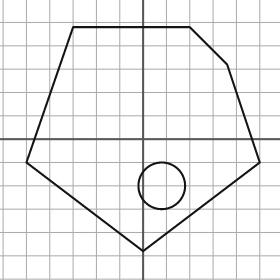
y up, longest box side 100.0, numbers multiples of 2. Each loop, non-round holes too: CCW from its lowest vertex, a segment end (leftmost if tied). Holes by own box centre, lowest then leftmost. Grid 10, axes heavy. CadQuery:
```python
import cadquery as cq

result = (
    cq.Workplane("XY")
    .moveTo(0.0, -48.0)
    .lineTo(50.0, -10.0)
    .lineTo(36.0, 32.0)
    .lineTo(20.0, 48.0)
    .lineTo(-30.0, 48.0)
    .lineTo(-50.0, -10.0)
    .close()
    .moveTo(8.0, -20.0)
    .circle(10.0)
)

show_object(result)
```